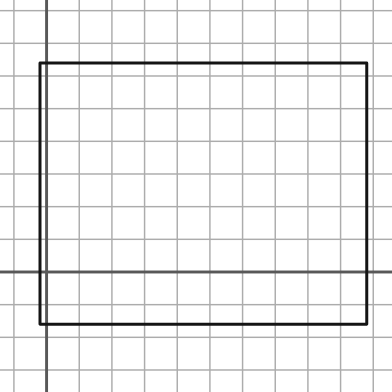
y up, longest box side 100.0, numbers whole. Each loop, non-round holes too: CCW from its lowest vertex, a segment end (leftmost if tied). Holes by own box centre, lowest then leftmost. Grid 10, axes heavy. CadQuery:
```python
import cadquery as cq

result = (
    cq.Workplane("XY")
    .moveTo(-2.0, -16.0)
    .lineTo(98.0, -16.0)
    .lineTo(98.0, 64.0)
    .lineTo(-2.0, 64.0)
    .close()
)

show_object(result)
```